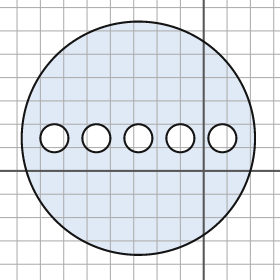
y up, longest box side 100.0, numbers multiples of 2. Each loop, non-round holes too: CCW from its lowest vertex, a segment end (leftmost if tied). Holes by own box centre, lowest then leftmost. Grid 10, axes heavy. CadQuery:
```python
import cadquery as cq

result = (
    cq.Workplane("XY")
    .moveTo(-28.0, 14.0)
    .circle(50.0)
    .moveTo(-64.0, 14.0)
    .circle(6.0)
    .moveTo(-46.0, 14.0)
    .circle(6.0)
    .moveTo(-28.0, 14.0)
    .circle(6.0)
    .moveTo(-10.0, 14.0)
    .circle(6.0)
    .moveTo(8.0, 14.0)
    .circle(6.0)
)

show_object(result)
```